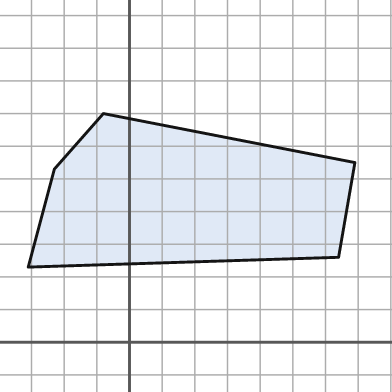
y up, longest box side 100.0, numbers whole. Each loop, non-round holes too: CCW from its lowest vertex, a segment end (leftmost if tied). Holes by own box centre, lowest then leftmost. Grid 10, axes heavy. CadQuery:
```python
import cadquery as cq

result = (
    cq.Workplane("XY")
    .moveTo(-31.0, 23.0)
    .lineTo(64.0, 26.0)
    .lineTo(69.0, 55.0)
    .lineTo(-8.0, 70.0)
    .lineTo(-23.0, 53.0)
    .close()
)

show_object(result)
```